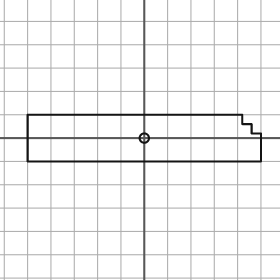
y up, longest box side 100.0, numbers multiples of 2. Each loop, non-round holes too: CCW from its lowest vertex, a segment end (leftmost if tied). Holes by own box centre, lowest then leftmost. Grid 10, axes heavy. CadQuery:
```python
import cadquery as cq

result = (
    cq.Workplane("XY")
    .moveTo(-50.0, -10.0)
    .lineTo(50.0, -10.0)
    .lineTo(50.0, 2.0)
    .lineTo(46.0, 2.0)
    .lineTo(46.0, 6.0)
    .lineTo(42.0, 6.0)
    .lineTo(42.0, 10.0)
    .lineTo(-50.0, 10.0)
    .close()
    .moveTo(0.0, 0.0)
    .circle(2.0)
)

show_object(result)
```